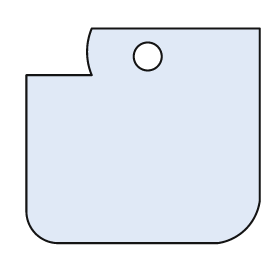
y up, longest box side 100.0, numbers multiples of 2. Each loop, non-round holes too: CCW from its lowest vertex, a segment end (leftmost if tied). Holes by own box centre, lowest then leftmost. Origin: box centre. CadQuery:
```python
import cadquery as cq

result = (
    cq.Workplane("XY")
    .moveTo(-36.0, -46.0)
    .lineTo(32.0, -46.0)
    .threePointArc((44.0, -40.0), (50.0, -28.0))
    .lineTo(50.0, 46.0)
    .lineTo(-22.0, 46.0)
    .threePointArc((-24.0, 36.0), (-22.0, 26.0))
    .lineTo(-50.0, 26.0)
    .lineTo(-50.0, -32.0)
    .threePointArc((-46.0, -42.0), (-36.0, -46.0))
    .close()
    .moveTo(2.0, 34.0)
    .circle(6.0)
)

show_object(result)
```